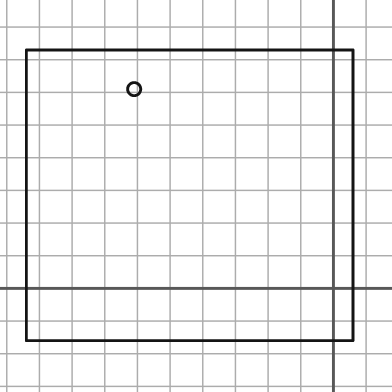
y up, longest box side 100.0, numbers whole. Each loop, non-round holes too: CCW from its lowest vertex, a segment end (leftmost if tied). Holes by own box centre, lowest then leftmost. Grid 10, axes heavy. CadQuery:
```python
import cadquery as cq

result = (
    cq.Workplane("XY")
    .moveTo(-94.0, -16.0)
    .lineTo(6.0, -16.0)
    .lineTo(6.0, 73.0)
    .lineTo(-94.0, 73.0)
    .close()
    .moveTo(-61.0, 61.0)
    .circle(2.0)
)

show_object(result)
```